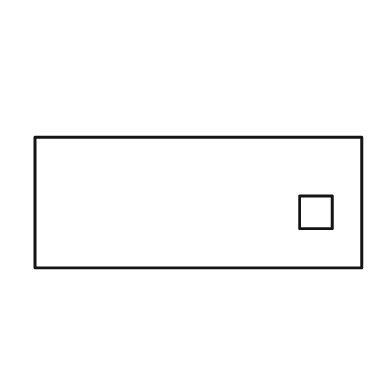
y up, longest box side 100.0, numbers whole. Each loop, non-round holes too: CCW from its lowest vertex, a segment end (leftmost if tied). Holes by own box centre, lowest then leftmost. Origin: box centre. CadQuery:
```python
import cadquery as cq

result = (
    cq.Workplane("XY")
    .moveTo(-50.0, -20.0)
    .lineTo(50.0, -20.0)
    .lineTo(50.0, 20.0)
    .lineTo(-50.0, 20.0)
    .close()
    .moveTo(31.0, -8.0)
    .lineTo(41.0, -8.0)
    .lineTo(41.0, 2.0)
    .lineTo(31.0, 2.0)
    .close()
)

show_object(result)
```